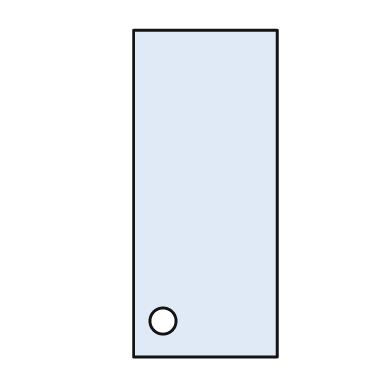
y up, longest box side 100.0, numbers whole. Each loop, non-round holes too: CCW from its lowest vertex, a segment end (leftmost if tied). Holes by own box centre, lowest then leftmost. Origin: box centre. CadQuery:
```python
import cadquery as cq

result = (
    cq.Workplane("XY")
    .moveTo(-22.0, -50.0)
    .lineTo(22.0, -50.0)
    .lineTo(22.0, 50.0)
    .lineTo(-22.0, 50.0)
    .close()
    .moveTo(-13.0, -39.0)
    .circle(4.0)
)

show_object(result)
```